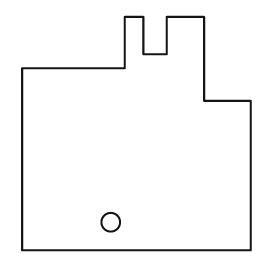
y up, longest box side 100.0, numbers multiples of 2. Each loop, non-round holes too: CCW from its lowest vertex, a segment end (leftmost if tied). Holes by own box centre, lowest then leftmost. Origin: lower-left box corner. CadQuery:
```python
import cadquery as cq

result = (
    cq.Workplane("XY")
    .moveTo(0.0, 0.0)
    .lineTo(98.0, 0.0)
    .lineTo(98.0, 64.0)
    .lineTo(78.0, 64.0)
    .lineTo(78.0, 100.0)
    .lineTo(62.0, 100.0)
    .lineTo(62.0, 84.0)
    .lineTo(52.0, 84.0)
    .lineTo(52.0, 100.0)
    .lineTo(44.0, 100.0)
    .lineTo(44.0, 78.0)
    .lineTo(0.0, 78.0)
    .close()
    .moveTo(38.0, 12.0)
    .circle(4.0)
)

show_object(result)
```